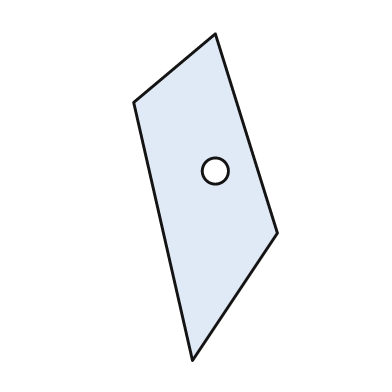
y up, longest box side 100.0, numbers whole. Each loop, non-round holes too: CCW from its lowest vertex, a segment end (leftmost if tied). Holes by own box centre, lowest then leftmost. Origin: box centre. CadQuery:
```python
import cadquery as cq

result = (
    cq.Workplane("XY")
    .moveTo(-4.0, -50.0)
    .lineTo(22.0, -11.0)
    .lineTo(3.0, 50.0)
    .lineTo(-22.0, 29.0)
    .close()
    .moveTo(3.0, 8.0)
    .circle(4.0)
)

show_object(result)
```